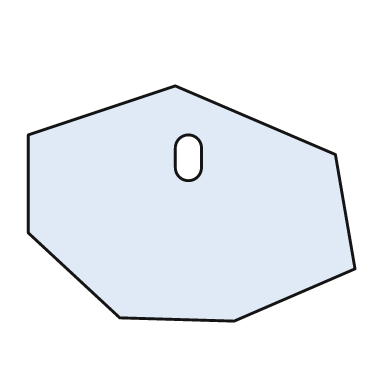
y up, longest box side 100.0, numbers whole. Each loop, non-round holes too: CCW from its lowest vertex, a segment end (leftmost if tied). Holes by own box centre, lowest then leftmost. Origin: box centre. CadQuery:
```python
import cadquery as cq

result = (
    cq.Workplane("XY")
    .moveTo(13.0, -36.0)
    .lineTo(50.0, -20.0)
    .lineTo(44.0, 15.0)
    .lineTo(-5.0, 36.0)
    .lineTo(-50.0, 21.0)
    .lineTo(-50.0, -9.0)
    .lineTo(-22.0, -35.0)
    .close()
    .moveTo(-5.0, 11.0)
    .threePointArc((-1.0, 7.0), (3.0, 11.0))
    .lineTo(3.0, 17.0)
    .threePointArc((-1.0, 21.0), (-5.0, 17.0))
    .close()
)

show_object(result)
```